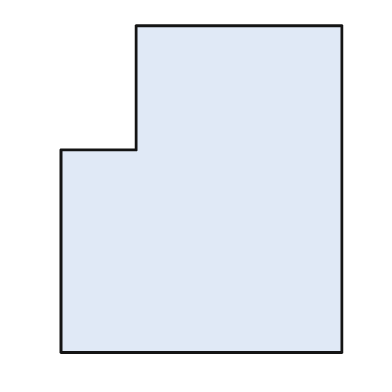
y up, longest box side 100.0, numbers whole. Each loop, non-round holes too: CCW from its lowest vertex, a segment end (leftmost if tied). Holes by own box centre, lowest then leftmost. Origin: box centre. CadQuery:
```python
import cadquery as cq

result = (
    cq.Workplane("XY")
    .moveTo(-43.0, -50.0)
    .lineTo(43.0, -50.0)
    .lineTo(43.0, 50.0)
    .lineTo(-20.0, 50.0)
    .lineTo(-20.0, 12.0)
    .lineTo(-43.0, 12.0)
    .close()
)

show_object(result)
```